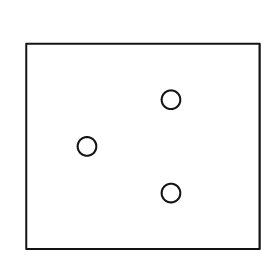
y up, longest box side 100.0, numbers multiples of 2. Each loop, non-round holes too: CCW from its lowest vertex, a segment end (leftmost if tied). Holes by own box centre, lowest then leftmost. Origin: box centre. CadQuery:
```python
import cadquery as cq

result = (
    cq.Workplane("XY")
    .moveTo(-50.0, -44.0)
    .lineTo(50.0, -44.0)
    .lineTo(50.0, 44.0)
    .lineTo(-50.0, 44.0)
    .close()
    .moveTo(12.0, -20.0)
    .circle(4.0)
    .moveTo(-24.0, 0.0)
    .circle(4.0)
    .moveTo(12.0, 20.0)
    .circle(4.0)
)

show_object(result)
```